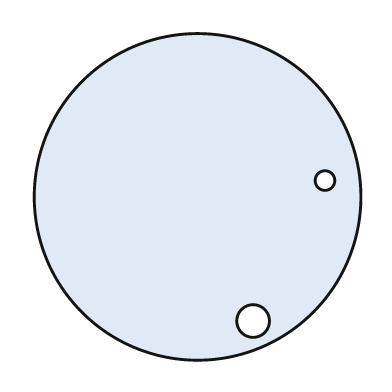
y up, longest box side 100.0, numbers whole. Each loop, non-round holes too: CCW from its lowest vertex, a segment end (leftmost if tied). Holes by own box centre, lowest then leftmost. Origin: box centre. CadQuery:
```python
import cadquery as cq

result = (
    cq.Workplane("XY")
    .moveTo(0.0, 0.0)
    .circle(50.0)
    .moveTo(17.0, -38.0)
    .circle(5.0)
    .moveTo(39.0, 5.0)
    .circle(3.0)
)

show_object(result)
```